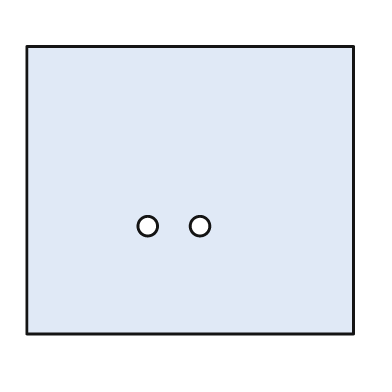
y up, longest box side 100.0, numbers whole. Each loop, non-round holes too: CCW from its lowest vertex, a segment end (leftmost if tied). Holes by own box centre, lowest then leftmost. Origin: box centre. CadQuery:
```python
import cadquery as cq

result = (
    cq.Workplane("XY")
    .moveTo(-50.0, -44.0)
    .lineTo(50.0, -44.0)
    .lineTo(50.0, 44.0)
    .lineTo(-50.0, 44.0)
    .close()
    .moveTo(-13.0, -11.0)
    .circle(3.0)
    .moveTo(3.0, -11.0)
    .circle(3.0)
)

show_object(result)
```